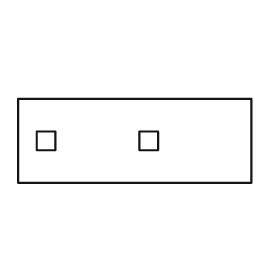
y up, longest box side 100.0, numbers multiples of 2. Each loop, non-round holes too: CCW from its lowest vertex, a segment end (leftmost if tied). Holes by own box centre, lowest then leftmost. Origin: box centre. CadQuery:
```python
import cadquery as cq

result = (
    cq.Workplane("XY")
    .moveTo(-50.0, -18.0)
    .lineTo(50.0, -18.0)
    .lineTo(50.0, 18.0)
    .lineTo(-50.0, 18.0)
    .close()
    .moveTo(-42.0, -4.0)
    .lineTo(-34.0, -4.0)
    .lineTo(-34.0, 4.0)
    .lineTo(-42.0, 4.0)
    .close()
    .moveTo(2.0, -4.0)
    .lineTo(10.0, -4.0)
    .lineTo(10.0, 4.0)
    .lineTo(2.0, 4.0)
    .close()
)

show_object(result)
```